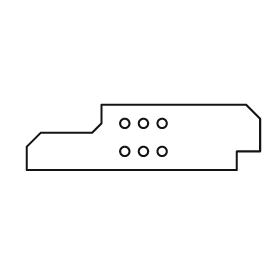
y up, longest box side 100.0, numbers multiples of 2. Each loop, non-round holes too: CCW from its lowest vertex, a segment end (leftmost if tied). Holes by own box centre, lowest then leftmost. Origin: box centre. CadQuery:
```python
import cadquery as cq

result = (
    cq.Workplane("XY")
    .moveTo(-50.0, -14.0)
    .lineTo(40.0, -14.0)
    .lineTo(40.0, -6.0)
    .lineTo(50.0, -6.0)
    .lineTo(50.0, 8.0)
    .lineTo(44.0, 14.0)
    .lineTo(-18.0, 14.0)
    .lineTo(-18.0, 6.0)
    .lineTo(-22.0, 2.0)
    .lineTo(-44.0, 2.0)
    .lineTo(-50.0, -4.0)
    .close()
    .moveTo(-8.0, -6.0)
    .circle(2.0)
    .moveTo(0.0, -6.0)
    .circle(2.0)
    .moveTo(8.0, -6.0)
    .circle(2.0)
    .moveTo(-8.0, 6.0)
    .circle(2.0)
    .moveTo(0.0, 6.0)
    .circle(2.0)
    .moveTo(8.0, 6.0)
    .circle(2.0)
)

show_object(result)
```